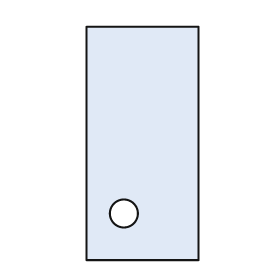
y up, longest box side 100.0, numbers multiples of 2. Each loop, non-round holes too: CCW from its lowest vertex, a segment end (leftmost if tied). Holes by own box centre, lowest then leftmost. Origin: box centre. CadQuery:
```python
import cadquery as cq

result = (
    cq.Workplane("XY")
    .moveTo(-24.0, -50.0)
    .lineTo(24.0, -50.0)
    .lineTo(24.0, 50.0)
    .lineTo(-24.0, 50.0)
    .close()
    .moveTo(-8.0, -30.0)
    .circle(6.0)
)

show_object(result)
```